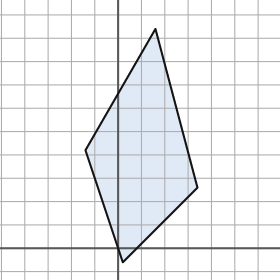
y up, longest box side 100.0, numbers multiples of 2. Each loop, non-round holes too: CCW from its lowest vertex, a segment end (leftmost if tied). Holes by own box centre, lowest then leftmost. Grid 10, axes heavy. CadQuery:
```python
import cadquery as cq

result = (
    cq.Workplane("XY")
    .moveTo(2.0, -6.0)
    .lineTo(34.0, 26.0)
    .lineTo(16.0, 94.0)
    .lineTo(-14.0, 42.0)
    .close()
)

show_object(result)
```